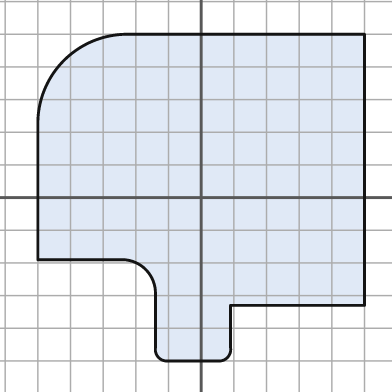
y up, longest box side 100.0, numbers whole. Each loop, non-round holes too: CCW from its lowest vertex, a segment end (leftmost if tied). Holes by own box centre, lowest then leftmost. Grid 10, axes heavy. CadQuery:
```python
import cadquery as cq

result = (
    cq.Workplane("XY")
    .moveTo(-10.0, -50.0)
    .lineTo(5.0, -50.0)
    .threePointArc((8.0, -49.0), (9.0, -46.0))
    .lineTo(9.0, -33.0)
    .lineTo(50.0, -33.0)
    .lineTo(50.0, 50.0)
    .lineTo(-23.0, 50.0)
    .threePointArc((-42.0, 42.0), (-50.0, 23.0))
    .lineTo(-50.0, -19.0)
    .lineTo(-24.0, -19.0)
    .threePointArc((-17.0, -22.0), (-14.0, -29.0))
    .lineTo(-14.0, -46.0)
    .threePointArc((-13.0, -49.0), (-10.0, -50.0))
    .close()
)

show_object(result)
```